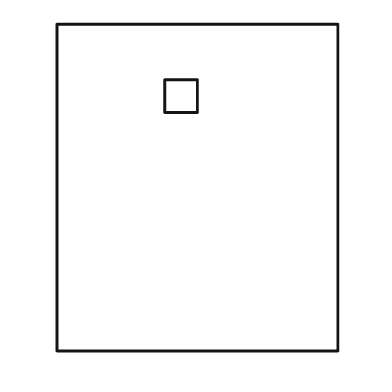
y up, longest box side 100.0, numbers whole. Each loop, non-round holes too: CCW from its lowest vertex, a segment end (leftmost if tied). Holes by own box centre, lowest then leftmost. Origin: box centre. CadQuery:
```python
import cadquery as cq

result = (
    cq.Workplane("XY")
    .moveTo(-43.0, -50.0)
    .lineTo(43.0, -50.0)
    .lineTo(43.0, 50.0)
    .lineTo(-43.0, 50.0)
    .close()
    .moveTo(-10.0, 23.0)
    .lineTo(0.0, 23.0)
    .lineTo(0.0, 33.0)
    .lineTo(-10.0, 33.0)
    .close()
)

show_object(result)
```